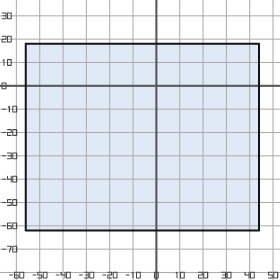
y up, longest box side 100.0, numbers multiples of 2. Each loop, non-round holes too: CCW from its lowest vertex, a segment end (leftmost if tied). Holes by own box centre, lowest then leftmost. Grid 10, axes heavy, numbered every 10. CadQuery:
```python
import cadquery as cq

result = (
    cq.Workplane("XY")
    .moveTo(-56.0, -62.0)
    .lineTo(44.0, -62.0)
    .lineTo(44.0, 18.0)
    .lineTo(-56.0, 18.0)
    .close()
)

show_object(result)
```